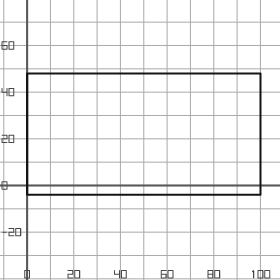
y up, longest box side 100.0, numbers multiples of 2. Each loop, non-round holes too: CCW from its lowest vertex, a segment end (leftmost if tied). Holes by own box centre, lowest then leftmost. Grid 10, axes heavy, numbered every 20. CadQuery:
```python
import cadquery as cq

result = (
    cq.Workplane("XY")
    .moveTo(0.0, -4.0)
    .lineTo(100.0, -4.0)
    .lineTo(100.0, 48.0)
    .lineTo(0.0, 48.0)
    .close()
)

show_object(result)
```